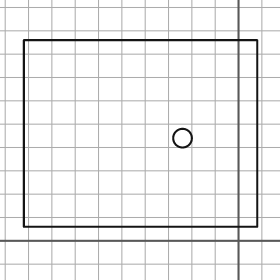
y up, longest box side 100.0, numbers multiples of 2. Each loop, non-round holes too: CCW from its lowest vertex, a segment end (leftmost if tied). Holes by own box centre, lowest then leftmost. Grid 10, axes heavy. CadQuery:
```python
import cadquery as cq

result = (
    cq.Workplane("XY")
    .moveTo(-92.0, 6.0)
    .lineTo(8.0, 6.0)
    .lineTo(8.0, 86.0)
    .lineTo(-92.0, 86.0)
    .close()
    .moveTo(-24.0, 44.0)
    .circle(4.0)
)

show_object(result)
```